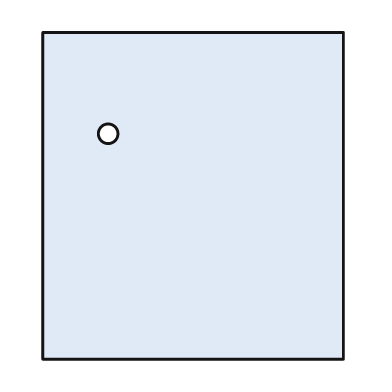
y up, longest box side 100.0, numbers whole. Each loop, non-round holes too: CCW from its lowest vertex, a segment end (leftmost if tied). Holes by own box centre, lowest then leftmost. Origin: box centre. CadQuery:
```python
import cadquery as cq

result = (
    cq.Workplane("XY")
    .moveTo(-46.0, -50.0)
    .lineTo(46.0, -50.0)
    .lineTo(46.0, 50.0)
    .lineTo(-46.0, 50.0)
    .close()
    .moveTo(-26.0, 19.0)
    .circle(3.0)
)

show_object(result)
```